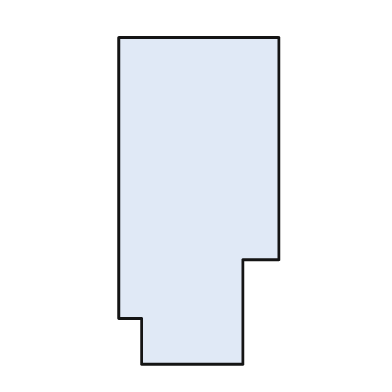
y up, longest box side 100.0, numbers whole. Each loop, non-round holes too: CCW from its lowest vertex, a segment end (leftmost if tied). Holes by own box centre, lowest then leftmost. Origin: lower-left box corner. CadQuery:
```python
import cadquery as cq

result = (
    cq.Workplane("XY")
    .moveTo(7.0, 0.0)
    .lineTo(38.0, 0.0)
    .lineTo(38.0, 32.0)
    .lineTo(49.0, 32.0)
    .lineTo(49.0, 100.0)
    .lineTo(0.0, 100.0)
    .lineTo(0.0, 14.0)
    .lineTo(7.0, 14.0)
    .close()
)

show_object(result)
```